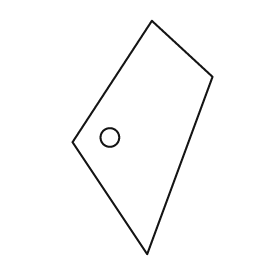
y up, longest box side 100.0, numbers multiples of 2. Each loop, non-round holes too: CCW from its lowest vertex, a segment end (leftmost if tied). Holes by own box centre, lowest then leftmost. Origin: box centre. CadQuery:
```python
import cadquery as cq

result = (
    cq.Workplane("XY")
    .moveTo(2.0, -50.0)
    .lineTo(30.0, 26.0)
    .lineTo(4.0, 50.0)
    .lineTo(-30.0, -2.0)
    .close()
    .moveTo(-14.0, 0.0)
    .circle(4.0)
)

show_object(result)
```